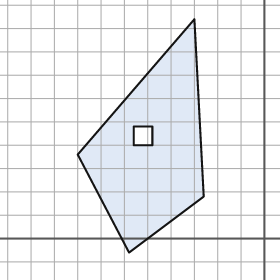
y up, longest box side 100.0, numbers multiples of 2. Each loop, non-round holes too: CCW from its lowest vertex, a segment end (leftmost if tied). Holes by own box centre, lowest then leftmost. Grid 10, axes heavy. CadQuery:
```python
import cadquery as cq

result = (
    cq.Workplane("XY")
    .moveTo(-58.0, -6.0)
    .lineTo(-26.0, 18.0)
    .lineTo(-30.0, 94.0)
    .lineTo(-80.0, 36.0)
    .close()
    .moveTo(-56.0, 40.0)
    .lineTo(-48.0, 40.0)
    .lineTo(-48.0, 48.0)
    .lineTo(-56.0, 48.0)
    .close()
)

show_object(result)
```